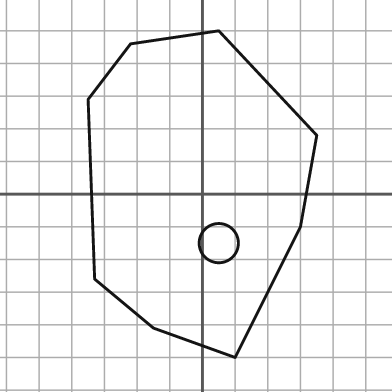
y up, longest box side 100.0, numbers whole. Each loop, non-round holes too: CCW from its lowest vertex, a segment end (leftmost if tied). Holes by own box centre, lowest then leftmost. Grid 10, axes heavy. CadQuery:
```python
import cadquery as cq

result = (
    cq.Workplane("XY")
    .moveTo(10.0, -50.0)
    .lineTo(30.0, -10.0)
    .lineTo(35.0, 18.0)
    .lineTo(5.0, 50.0)
    .lineTo(-22.0, 46.0)
    .lineTo(-35.0, 29.0)
    .lineTo(-33.0, -26.0)
    .lineTo(-15.0, -41.0)
    .close()
    .moveTo(5.0, -15.0)
    .circle(6.0)
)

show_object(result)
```